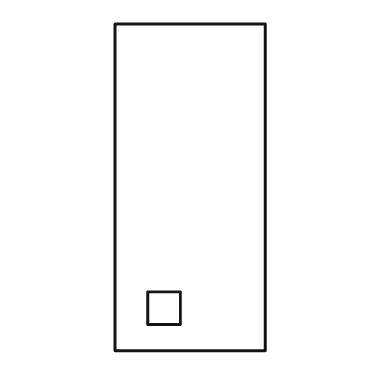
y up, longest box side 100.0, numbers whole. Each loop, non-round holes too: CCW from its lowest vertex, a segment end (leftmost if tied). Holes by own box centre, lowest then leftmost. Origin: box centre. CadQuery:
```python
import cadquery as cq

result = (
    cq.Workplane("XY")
    .moveTo(-23.0, -50.0)
    .lineTo(23.0, -50.0)
    .lineTo(23.0, 50.0)
    .lineTo(-23.0, 50.0)
    .close()
    .moveTo(-13.0, -42.0)
    .lineTo(-3.0, -42.0)
    .lineTo(-3.0, -32.0)
    .lineTo(-13.0, -32.0)
    .close()
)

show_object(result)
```